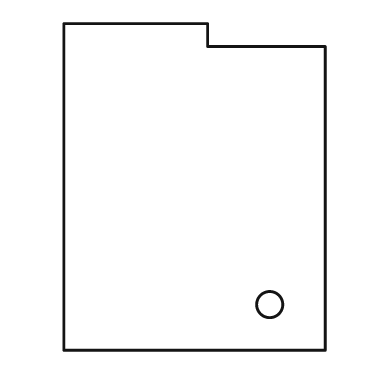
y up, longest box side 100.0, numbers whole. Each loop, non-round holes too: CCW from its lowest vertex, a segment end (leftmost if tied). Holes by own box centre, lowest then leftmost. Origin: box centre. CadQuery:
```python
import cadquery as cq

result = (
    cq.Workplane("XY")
    .moveTo(-40.0, -50.0)
    .lineTo(40.0, -50.0)
    .lineTo(40.0, 43.0)
    .lineTo(4.0, 43.0)
    .lineTo(4.0, 50.0)
    .lineTo(-40.0, 50.0)
    .close()
    .moveTo(23.0, -36.0)
    .circle(4.0)
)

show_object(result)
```